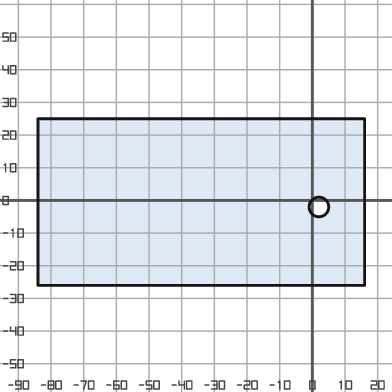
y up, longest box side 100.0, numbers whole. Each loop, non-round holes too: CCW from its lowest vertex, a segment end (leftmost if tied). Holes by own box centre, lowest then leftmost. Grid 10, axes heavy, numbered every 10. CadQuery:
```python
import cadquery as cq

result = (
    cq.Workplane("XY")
    .moveTo(-84.0, -26.0)
    .lineTo(16.0, -26.0)
    .lineTo(16.0, 25.0)
    .lineTo(-84.0, 25.0)
    .close()
    .moveTo(2.0, -2.0)
    .circle(3.0)
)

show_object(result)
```